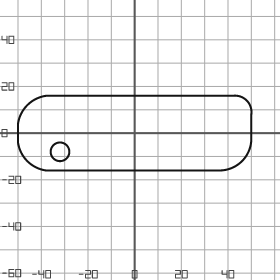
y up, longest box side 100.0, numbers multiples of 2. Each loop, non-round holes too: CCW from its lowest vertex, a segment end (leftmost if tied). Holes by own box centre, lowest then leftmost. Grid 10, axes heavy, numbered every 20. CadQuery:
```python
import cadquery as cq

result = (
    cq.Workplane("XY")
    .moveTo(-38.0, -16.0)
    .lineTo(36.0, -16.0)
    .threePointArc((46.0, -12.0), (50.0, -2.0))
    .lineTo(50.0, 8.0)
    .threePointArc((48.0, 14.0), (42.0, 16.0))
    .lineTo(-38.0, 16.0)
    .threePointArc((-46.0, 12.0), (-50.0, 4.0))
    .lineTo(-50.0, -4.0)
    .threePointArc((-46.0, -12.0), (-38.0, -16.0))
    .close()
    .moveTo(-32.0, -8.0)
    .circle(4.0)
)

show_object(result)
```